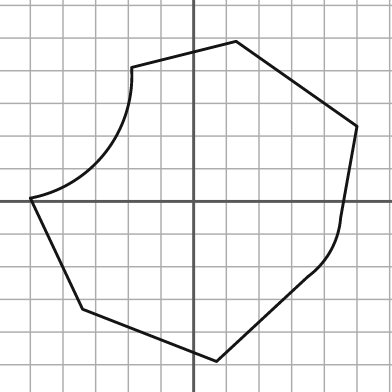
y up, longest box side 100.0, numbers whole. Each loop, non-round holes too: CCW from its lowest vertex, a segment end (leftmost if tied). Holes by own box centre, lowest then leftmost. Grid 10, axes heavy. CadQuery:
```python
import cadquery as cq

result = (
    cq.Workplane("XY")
    .moveTo(7.0, -49.0)
    .lineTo(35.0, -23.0)
    .threePointArc((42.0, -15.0), (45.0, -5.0))
    .lineTo(50.0, 23.0)
    .lineTo(13.0, 49.0)
    .lineTo(-19.0, 41.0)
    .threePointArc((-27.0, 15.0), (-50.0, 1.0))
    .lineTo(-34.0, -33.0)
    .close()
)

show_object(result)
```